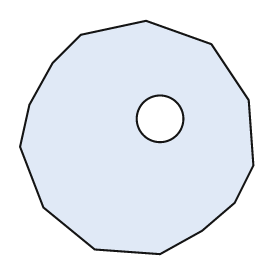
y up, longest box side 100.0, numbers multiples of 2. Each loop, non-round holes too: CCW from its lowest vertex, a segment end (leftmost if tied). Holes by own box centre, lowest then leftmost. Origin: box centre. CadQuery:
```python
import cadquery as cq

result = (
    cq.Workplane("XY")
    .moveTo(10.0, -50.0)
    .lineTo(28.0, -40.0)
    .lineTo(42.0, -28.0)
    .lineTo(50.0, -12.0)
    .lineTo(48.0, 16.0)
    .lineTo(32.0, 40.0)
    .lineTo(4.0, 50.0)
    .lineTo(-24.0, 44.0)
    .lineTo(-36.0, 32.0)
    .lineTo(-46.0, 14.0)
    .lineTo(-50.0, -4.0)
    .lineTo(-40.0, -30.0)
    .lineTo(-18.0, -48.0)
    .close()
    .moveTo(10.0, 8.0)
    .circle(10.0)
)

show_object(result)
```